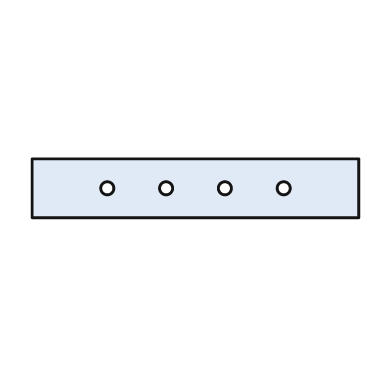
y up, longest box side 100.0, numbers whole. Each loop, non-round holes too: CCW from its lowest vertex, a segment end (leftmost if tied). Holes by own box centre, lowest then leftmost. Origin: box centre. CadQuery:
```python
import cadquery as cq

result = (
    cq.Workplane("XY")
    .moveTo(-50.0, -9.0)
    .lineTo(50.0, -9.0)
    .lineTo(50.0, 9.0)
    .lineTo(-50.0, 9.0)
    .close()
    .moveTo(-27.0, 0.0)
    .circle(2.0)
    .moveTo(-9.0, 0.0)
    .circle(2.0)
    .moveTo(9.0, 0.0)
    .circle(2.0)
    .moveTo(27.0, 0.0)
    .circle(2.0)
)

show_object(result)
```